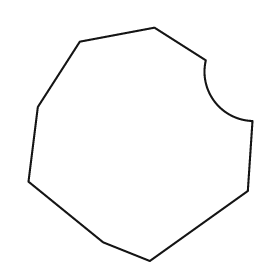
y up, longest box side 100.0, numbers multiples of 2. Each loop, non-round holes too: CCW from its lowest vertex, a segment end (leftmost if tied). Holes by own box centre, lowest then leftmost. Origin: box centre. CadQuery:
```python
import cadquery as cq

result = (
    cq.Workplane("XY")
    .moveTo(4.0, -50.0)
    .lineTo(46.0, -20.0)
    .lineTo(48.0, 10.0)
    .threePointArc((32.0, 18.0), (28.0, 36.0))
    .lineTo(6.0, 50.0)
    .lineTo(-26.0, 44.0)
    .lineTo(-44.0, 16.0)
    .lineTo(-48.0, -16.0)
    .lineTo(-16.0, -42.0)
    .close()
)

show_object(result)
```